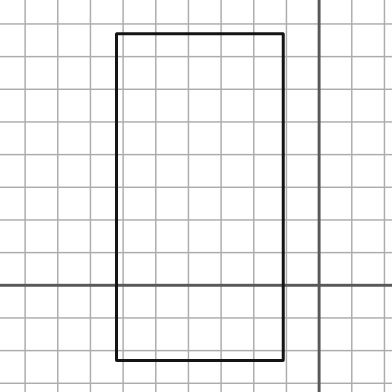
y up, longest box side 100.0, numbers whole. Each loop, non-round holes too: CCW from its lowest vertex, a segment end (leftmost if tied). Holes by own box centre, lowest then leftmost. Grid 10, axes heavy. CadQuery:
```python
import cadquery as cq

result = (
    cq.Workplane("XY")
    .moveTo(-62.0, -23.0)
    .lineTo(-11.0, -23.0)
    .lineTo(-11.0, 77.0)
    .lineTo(-62.0, 77.0)
    .close()
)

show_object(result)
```